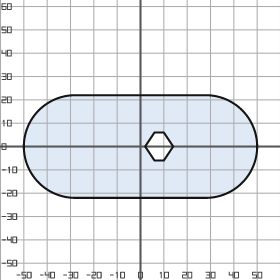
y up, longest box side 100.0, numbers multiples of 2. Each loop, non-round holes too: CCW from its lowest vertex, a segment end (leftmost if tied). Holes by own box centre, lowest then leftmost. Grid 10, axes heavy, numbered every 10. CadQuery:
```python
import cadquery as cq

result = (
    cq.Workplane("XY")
    .moveTo(-28.0, -22.0)
    .lineTo(28.0, -22.0)
    .threePointArc((50.0, 0.0), (28.0, 22.0))
    .lineTo(-28.0, 22.0)
    .threePointArc((-50.0, 0.0), (-28.0, -22.0))
    .close()
    .moveTo(6.0, -6.0)
    .lineTo(10.0, -6.0)
    .lineTo(14.0, 0.0)
    .lineTo(10.0, 6.0)
    .lineTo(6.0, 6.0)
    .lineTo(2.0, 0.0)
    .close()
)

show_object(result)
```